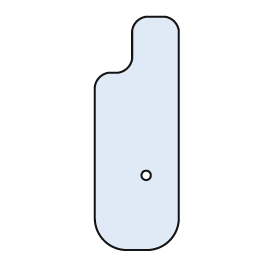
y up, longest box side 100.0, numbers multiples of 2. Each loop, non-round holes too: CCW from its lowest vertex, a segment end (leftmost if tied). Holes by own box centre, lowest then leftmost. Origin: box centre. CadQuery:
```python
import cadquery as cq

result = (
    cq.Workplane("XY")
    .moveTo(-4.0, -50.0)
    .lineTo(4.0, -50.0)
    .threePointArc((14.0, -46.0), (18.0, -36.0))
    .lineTo(18.0, 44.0)
    .threePointArc((16.0, 48.0), (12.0, 50.0))
    .lineTo(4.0, 50.0)
    .threePointArc((0.0, 48.0), (-2.0, 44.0))
    .lineTo(-2.0, 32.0)
    .threePointArc((-4.0, 28.0), (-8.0, 26.0))
    .lineTo(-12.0, 26.0)
    .threePointArc((-16.0, 24.0), (-18.0, 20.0))
    .lineTo(-18.0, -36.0)
    .threePointArc((-14.0, -46.0), (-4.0, -50.0))
    .close()
    .moveTo(4.0, -18.0)
    .circle(2.0)
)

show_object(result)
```